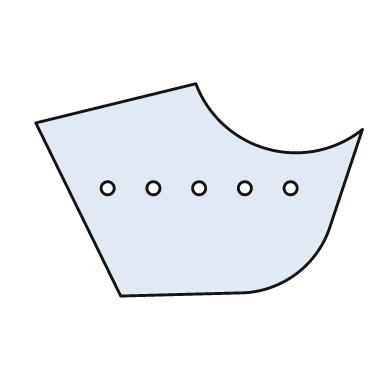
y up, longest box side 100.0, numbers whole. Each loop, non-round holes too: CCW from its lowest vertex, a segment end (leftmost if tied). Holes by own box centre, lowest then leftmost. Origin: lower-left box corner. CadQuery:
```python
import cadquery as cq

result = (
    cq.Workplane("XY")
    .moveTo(26.0, 0.0)
    .lineTo(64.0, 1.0)
    .threePointArc((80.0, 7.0), (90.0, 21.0))
    .lineTo(100.0, 51.0)
    .threePointArc((71.0, 45.0), (49.0, 65.0))
    .lineTo(0.0, 53.0)
    .close()
    .moveTo(22.0, 33.0)
    .circle(2.0)
    .moveTo(36.0, 33.0)
    .circle(2.0)
    .moveTo(50.0, 33.0)
    .circle(2.0)
    .moveTo(64.0, 33.0)
    .circle(2.0)
    .moveTo(78.0, 33.0)
    .circle(2.0)
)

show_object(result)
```